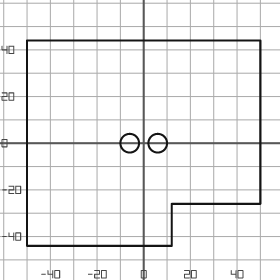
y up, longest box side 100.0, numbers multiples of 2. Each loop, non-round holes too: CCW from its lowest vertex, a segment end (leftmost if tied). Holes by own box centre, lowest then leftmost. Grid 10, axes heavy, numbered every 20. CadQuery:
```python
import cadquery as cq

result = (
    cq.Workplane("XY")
    .moveTo(-50.0, -44.0)
    .lineTo(12.0, -44.0)
    .lineTo(12.0, -26.0)
    .lineTo(50.0, -26.0)
    .lineTo(50.0, 44.0)
    .lineTo(-50.0, 44.0)
    .close()
    .moveTo(-6.0, 0.0)
    .circle(4.0)
    .moveTo(6.0, 0.0)
    .circle(4.0)
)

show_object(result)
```